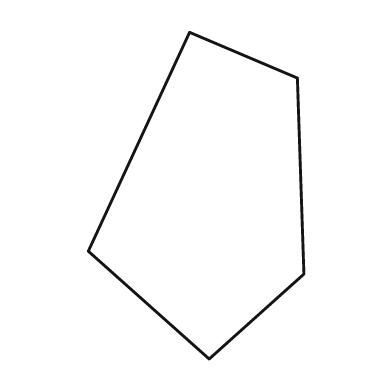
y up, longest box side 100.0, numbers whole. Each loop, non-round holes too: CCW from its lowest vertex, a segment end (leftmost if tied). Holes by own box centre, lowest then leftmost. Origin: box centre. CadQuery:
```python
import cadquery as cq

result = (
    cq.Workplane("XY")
    .moveTo(4.0, -50.0)
    .lineTo(33.0, -24.0)
    .lineTo(31.0, 36.0)
    .lineTo(-2.0, 50.0)
    .lineTo(-33.0, -17.0)
    .close()
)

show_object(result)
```